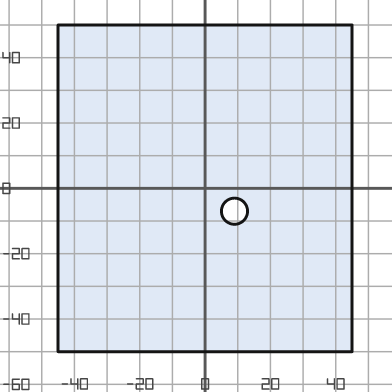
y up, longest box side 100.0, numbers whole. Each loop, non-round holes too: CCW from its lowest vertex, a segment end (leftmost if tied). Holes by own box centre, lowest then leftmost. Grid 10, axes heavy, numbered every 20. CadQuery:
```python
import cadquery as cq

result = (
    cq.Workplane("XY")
    .moveTo(-45.0, -50.0)
    .lineTo(45.0, -50.0)
    .lineTo(45.0, 50.0)
    .lineTo(-45.0, 50.0)
    .close()
    .moveTo(9.0, -7.0)
    .circle(4.0)
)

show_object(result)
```